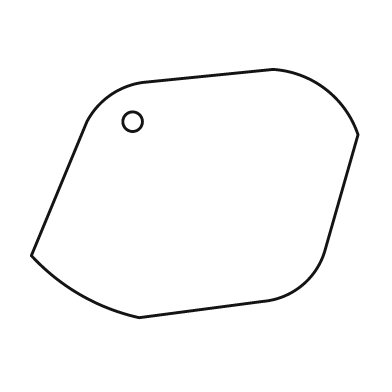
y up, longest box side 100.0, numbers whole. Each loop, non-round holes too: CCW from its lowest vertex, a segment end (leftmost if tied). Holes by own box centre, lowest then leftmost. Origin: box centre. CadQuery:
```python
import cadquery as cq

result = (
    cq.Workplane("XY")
    .moveTo(-17.0, -38.0)
    .lineTo(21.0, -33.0)
    .threePointArc((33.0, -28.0), (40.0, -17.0))
    .lineTo(50.0, 18.0)
    .threePointArc((40.0, 32.0), (24.0, 38.0))
    .lineTo(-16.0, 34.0)
    .threePointArc((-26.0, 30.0), (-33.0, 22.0))
    .lineTo(-50.0, -19.0)
    .threePointArc((-35.0, -31.0), (-17.0, -38.0))
    .close()
    .moveTo(-19.0, 22.0)
    .circle(3.0)
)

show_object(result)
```